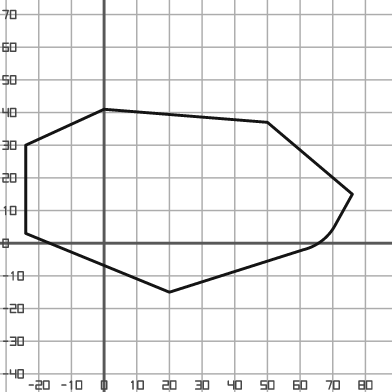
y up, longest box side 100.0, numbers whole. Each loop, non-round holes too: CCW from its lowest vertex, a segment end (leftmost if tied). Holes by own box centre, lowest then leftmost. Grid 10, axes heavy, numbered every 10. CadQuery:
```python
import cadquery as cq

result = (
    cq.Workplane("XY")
    .moveTo(20.0, -15.0)
    .lineTo(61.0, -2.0)
    .threePointArc((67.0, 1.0), (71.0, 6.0))
    .lineTo(76.0, 15.0)
    .lineTo(50.0, 37.0)
    .lineTo(0.0, 41.0)
    .lineTo(-24.0, 30.0)
    .lineTo(-24.0, 3.0)
    .close()
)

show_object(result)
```